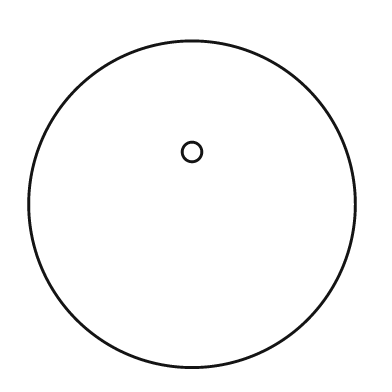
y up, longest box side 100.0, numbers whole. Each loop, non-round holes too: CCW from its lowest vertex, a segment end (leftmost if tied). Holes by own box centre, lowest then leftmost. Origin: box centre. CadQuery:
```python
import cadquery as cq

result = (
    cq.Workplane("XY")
    .moveTo(0.0, 0.0)
    .circle(50.0)
    .moveTo(0.0, 16.0)
    .circle(3.0)
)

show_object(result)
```